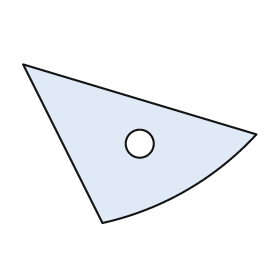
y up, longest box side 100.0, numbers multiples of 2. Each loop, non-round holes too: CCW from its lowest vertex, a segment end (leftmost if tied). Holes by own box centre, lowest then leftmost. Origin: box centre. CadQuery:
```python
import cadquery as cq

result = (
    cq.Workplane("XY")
    .moveTo(-16.0, -34.0)
    .threePointArc((20.0, -20.0), (50.0, 4.0))
    .lineTo(-50.0, 34.0)
    .close()
    .moveTo(0.0, 0.0)
    .circle(6.0)
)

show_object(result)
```